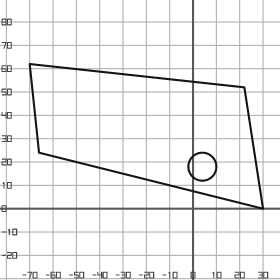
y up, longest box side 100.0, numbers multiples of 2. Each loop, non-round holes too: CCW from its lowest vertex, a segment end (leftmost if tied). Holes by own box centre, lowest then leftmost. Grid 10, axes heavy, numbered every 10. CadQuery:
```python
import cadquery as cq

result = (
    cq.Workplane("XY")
    .moveTo(30.0, 0.0)
    .lineTo(22.0, 52.0)
    .lineTo(-70.0, 62.0)
    .lineTo(-66.0, 24.0)
    .close()
    .moveTo(4.0, 18.0)
    .circle(6.0)
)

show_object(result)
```